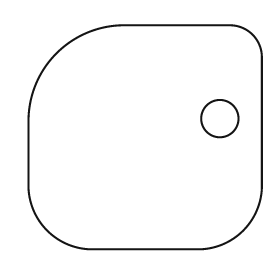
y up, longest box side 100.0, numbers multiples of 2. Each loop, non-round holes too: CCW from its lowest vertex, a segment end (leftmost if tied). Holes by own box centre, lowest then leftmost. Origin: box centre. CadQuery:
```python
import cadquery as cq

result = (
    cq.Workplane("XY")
    .moveTo(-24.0, -48.0)
    .lineTo(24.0, -48.0)
    .threePointArc((42.0, -40.0), (50.0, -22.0))
    .lineTo(50.0, 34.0)
    .threePointArc((46.0, 44.0), (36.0, 48.0))
    .lineTo(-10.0, 48.0)
    .threePointArc((-38.0, 36.0), (-50.0, 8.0))
    .lineTo(-50.0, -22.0)
    .threePointArc((-42.0, -40.0), (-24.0, -48.0))
    .close()
    .moveTo(32.0, 8.0)
    .circle(8.0)
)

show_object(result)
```